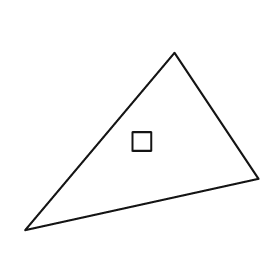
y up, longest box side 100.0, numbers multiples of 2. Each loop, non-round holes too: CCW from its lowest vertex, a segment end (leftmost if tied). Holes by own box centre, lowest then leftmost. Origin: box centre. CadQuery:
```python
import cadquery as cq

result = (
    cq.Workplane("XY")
    .moveTo(-50.0, -38.0)
    .lineTo(50.0, -16.0)
    .lineTo(14.0, 38.0)
    .close()
    .moveTo(-4.0, -4.0)
    .lineTo(4.0, -4.0)
    .lineTo(4.0, 4.0)
    .lineTo(-4.0, 4.0)
    .close()
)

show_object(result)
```